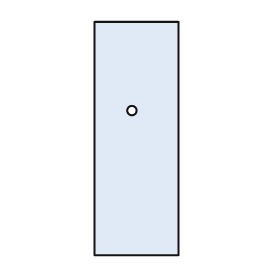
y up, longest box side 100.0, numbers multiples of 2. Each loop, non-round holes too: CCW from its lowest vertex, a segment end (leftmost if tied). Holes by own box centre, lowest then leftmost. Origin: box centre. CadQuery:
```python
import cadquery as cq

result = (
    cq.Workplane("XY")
    .moveTo(-18.0, -50.0)
    .lineTo(18.0, -50.0)
    .lineTo(18.0, 50.0)
    .lineTo(-18.0, 50.0)
    .close()
    .moveTo(-2.0, 12.0)
    .circle(2.0)
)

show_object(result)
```